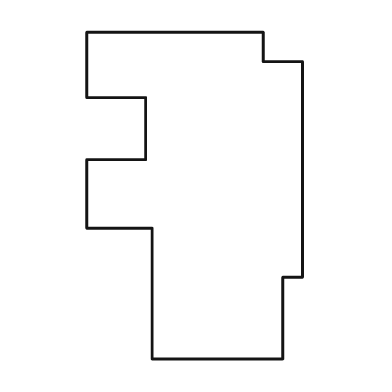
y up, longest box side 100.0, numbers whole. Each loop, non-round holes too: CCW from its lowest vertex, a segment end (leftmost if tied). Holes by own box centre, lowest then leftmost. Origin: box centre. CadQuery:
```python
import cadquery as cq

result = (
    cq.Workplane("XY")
    .moveTo(-13.0, -50.0)
    .lineTo(27.0, -50.0)
    .lineTo(27.0, -25.0)
    .lineTo(33.0, -25.0)
    .lineTo(33.0, 41.0)
    .lineTo(21.0, 41.0)
    .lineTo(21.0, 50.0)
    .lineTo(-33.0, 50.0)
    .lineTo(-33.0, 30.0)
    .lineTo(-15.0, 30.0)
    .lineTo(-15.0, 11.0)
    .lineTo(-33.0, 11.0)
    .lineTo(-33.0, -10.0)
    .lineTo(-13.0, -10.0)
    .close()
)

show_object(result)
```